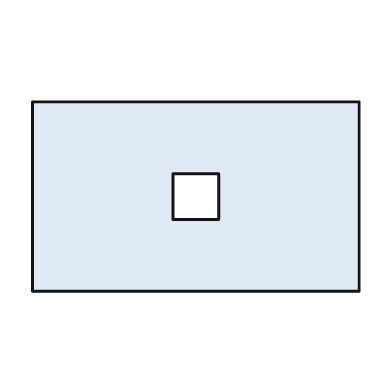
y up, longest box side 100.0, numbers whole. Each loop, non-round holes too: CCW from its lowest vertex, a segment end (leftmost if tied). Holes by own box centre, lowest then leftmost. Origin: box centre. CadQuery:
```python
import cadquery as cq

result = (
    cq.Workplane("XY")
    .moveTo(-50.0, -29.0)
    .lineTo(50.0, -29.0)
    .lineTo(50.0, 29.0)
    .lineTo(-50.0, 29.0)
    .close()
    .moveTo(-7.0, -7.0)
    .lineTo(7.0, -7.0)
    .lineTo(7.0, 7.0)
    .lineTo(-7.0, 7.0)
    .close()
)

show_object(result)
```